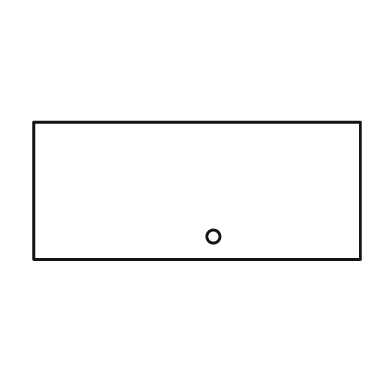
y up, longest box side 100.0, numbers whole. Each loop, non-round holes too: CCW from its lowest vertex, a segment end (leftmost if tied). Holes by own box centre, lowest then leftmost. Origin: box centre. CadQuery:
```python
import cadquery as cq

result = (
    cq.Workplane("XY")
    .moveTo(-50.0, -21.0)
    .lineTo(50.0, -21.0)
    .lineTo(50.0, 21.0)
    .lineTo(-50.0, 21.0)
    .close()
    .moveTo(5.0, -14.0)
    .circle(2.0)
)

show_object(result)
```